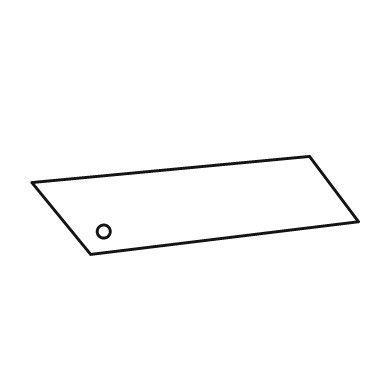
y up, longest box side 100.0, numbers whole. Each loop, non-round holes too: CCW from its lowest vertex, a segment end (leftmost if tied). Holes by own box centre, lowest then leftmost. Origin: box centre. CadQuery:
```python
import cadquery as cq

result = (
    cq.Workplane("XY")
    .moveTo(-32.0, -15.0)
    .lineTo(50.0, -5.0)
    .lineTo(35.0, 15.0)
    .lineTo(-50.0, 7.0)
    .close()
    .moveTo(-28.0, -8.0)
    .circle(2.0)
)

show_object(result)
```